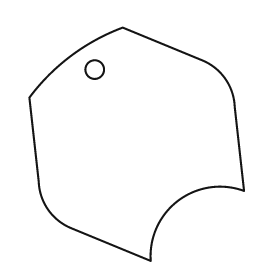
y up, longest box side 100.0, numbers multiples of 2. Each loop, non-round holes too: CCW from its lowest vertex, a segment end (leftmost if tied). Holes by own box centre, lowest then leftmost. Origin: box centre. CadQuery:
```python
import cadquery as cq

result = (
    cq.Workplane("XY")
    .moveTo(6.0, -50.0)
    .threePointArc((18.0, -24.0), (46.0, -20.0))
    .lineTo(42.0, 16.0)
    .threePointArc((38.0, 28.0), (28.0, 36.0))
    .lineTo(-6.0, 50.0)
    .threePointArc((-28.0, 38.0), (-46.0, 20.0))
    .lineTo(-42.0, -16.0)
    .threePointArc((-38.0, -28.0), (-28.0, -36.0))
    .close()
    .moveTo(-18.0, 32.0)
    .circle(4.0)
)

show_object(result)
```